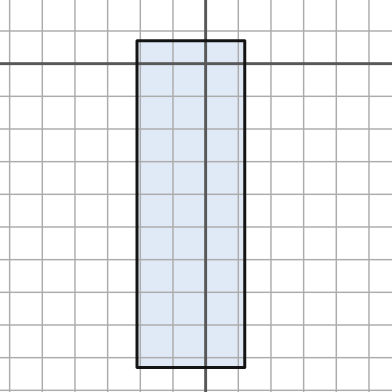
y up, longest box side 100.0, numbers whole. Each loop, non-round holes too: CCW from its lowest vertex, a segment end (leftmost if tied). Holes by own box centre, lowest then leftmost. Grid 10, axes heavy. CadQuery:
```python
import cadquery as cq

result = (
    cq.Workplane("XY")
    .moveTo(-21.0, -93.0)
    .lineTo(12.0, -93.0)
    .lineTo(12.0, 7.0)
    .lineTo(-21.0, 7.0)
    .close()
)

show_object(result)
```